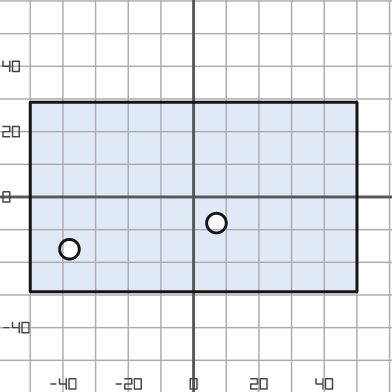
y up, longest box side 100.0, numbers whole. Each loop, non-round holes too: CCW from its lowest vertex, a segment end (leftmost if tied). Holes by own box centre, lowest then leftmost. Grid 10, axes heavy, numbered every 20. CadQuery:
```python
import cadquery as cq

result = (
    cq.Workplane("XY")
    .moveTo(-50.0, -29.0)
    .lineTo(50.0, -29.0)
    .lineTo(50.0, 29.0)
    .lineTo(-50.0, 29.0)
    .close()
    .moveTo(-38.0, -16.0)
    .circle(3.0)
    .moveTo(7.0, -8.0)
    .circle(3.0)
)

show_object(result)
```